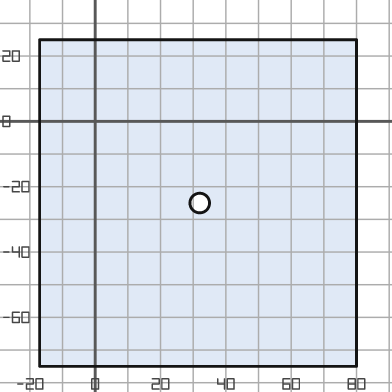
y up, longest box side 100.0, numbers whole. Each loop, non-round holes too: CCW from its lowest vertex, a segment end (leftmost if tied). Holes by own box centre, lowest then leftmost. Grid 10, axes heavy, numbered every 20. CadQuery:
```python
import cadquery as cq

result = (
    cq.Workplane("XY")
    .moveTo(-17.0, -75.0)
    .lineTo(80.0, -75.0)
    .lineTo(80.0, 25.0)
    .lineTo(-17.0, 25.0)
    .close()
    .moveTo(32.0, -25.0)
    .circle(3.0)
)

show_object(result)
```